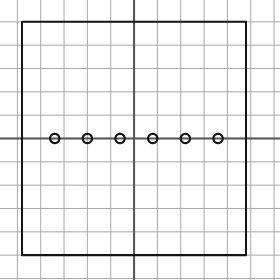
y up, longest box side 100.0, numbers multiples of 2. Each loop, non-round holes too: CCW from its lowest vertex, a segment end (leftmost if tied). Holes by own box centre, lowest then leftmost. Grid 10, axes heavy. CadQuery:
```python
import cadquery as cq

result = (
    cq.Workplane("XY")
    .moveTo(-48.0, -50.0)
    .lineTo(48.0, -50.0)
    .lineTo(48.0, 50.0)
    .lineTo(-48.0, 50.0)
    .close()
    .moveTo(-34.0, 0.0)
    .circle(2.0)
    .moveTo(-20.0, 0.0)
    .circle(2.0)
    .moveTo(-6.0, 0.0)
    .circle(2.0)
    .moveTo(8.0, 0.0)
    .circle(2.0)
    .moveTo(22.0, 0.0)
    .circle(2.0)
    .moveTo(36.0, 0.0)
    .circle(2.0)
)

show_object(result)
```